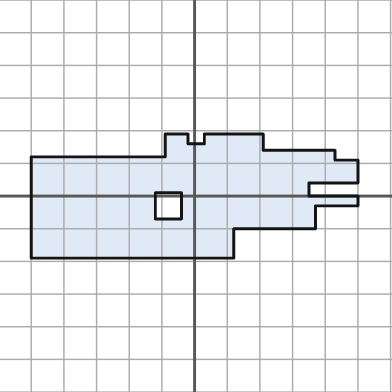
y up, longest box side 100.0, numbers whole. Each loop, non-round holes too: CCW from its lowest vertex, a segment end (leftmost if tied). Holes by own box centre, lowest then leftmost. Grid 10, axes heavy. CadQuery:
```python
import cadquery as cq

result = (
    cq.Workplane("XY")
    .moveTo(-50.0, -19.0)
    .lineTo(12.0, -19.0)
    .lineTo(12.0, -10.0)
    .lineTo(37.0, -10.0)
    .lineTo(37.0, -3.0)
    .lineTo(50.0, -3.0)
    .lineTo(50.0, 0.0)
    .lineTo(35.0, 0.0)
    .lineTo(35.0, 4.0)
    .lineTo(50.0, 4.0)
    .lineTo(50.0, 11.0)
    .lineTo(43.0, 11.0)
    .lineTo(43.0, 14.0)
    .lineTo(21.0, 14.0)
    .lineTo(21.0, 19.0)
    .lineTo(3.0, 19.0)
    .lineTo(3.0, 16.0)
    .lineTo(-2.0, 16.0)
    .lineTo(-2.0, 19.0)
    .lineTo(-9.0, 19.0)
    .lineTo(-9.0, 12.0)
    .lineTo(-50.0, 12.0)
    .close()
    .moveTo(-12.0, -7.0)
    .lineTo(-4.0, -7.0)
    .lineTo(-4.0, 1.0)
    .lineTo(-12.0, 1.0)
    .close()
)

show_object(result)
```